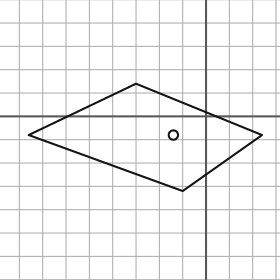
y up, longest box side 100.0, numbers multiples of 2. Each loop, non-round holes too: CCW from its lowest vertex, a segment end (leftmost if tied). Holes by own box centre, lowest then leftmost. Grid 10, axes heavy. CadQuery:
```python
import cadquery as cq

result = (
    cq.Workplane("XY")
    .moveTo(-10.0, -32.0)
    .lineTo(24.0, -8.0)
    .lineTo(-30.0, 14.0)
    .lineTo(-76.0, -8.0)
    .close()
    .moveTo(-14.0, -8.0)
    .circle(2.0)
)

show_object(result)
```